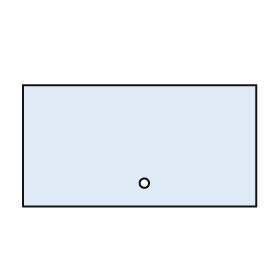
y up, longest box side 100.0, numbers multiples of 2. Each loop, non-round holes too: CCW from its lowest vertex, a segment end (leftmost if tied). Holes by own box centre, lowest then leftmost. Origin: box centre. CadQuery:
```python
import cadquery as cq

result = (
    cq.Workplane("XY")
    .moveTo(-50.0, -26.0)
    .lineTo(50.0, -26.0)
    .lineTo(50.0, 26.0)
    .lineTo(-50.0, 26.0)
    .close()
    .moveTo(2.0, -16.0)
    .circle(2.0)
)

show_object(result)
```